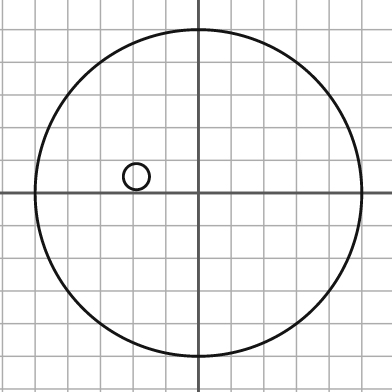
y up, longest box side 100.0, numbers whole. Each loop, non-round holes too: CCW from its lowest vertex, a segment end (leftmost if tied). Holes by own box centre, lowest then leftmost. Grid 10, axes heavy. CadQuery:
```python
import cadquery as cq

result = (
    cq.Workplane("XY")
    .moveTo(0.0, 0.0)
    .circle(50.0)
    .moveTo(-19.0, 5.0)
    .circle(4.0)
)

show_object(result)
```